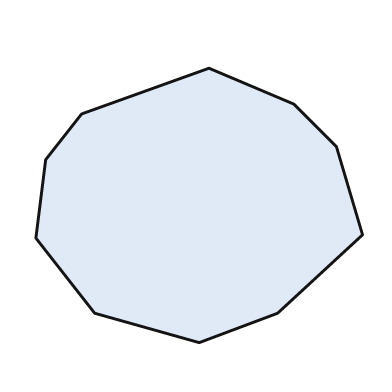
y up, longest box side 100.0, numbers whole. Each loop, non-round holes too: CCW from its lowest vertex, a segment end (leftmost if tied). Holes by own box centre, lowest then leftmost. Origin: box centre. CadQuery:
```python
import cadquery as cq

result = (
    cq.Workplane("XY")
    .moveTo(0.0, -42.0)
    .lineTo(24.0, -33.0)
    .lineTo(50.0, -9.0)
    .lineTo(42.0, 18.0)
    .lineTo(29.0, 31.0)
    .lineTo(3.0, 42.0)
    .lineTo(-36.0, 28.0)
    .lineTo(-47.0, 14.0)
    .lineTo(-50.0, -10.0)
    .lineTo(-32.0, -33.0)
    .close()
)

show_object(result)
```